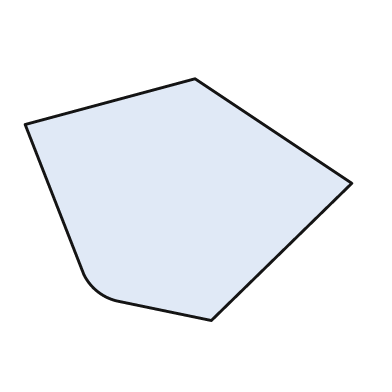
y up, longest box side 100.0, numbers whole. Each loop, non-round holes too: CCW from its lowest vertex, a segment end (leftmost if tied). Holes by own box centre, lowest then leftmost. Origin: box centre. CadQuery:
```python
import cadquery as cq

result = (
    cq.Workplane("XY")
    .moveTo(7.0, -37.0)
    .lineTo(50.0, 5.0)
    .lineTo(2.0, 37.0)
    .lineTo(-50.0, 23.0)
    .lineTo(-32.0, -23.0)
    .threePointArc((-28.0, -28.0), (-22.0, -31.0))
    .close()
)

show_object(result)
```